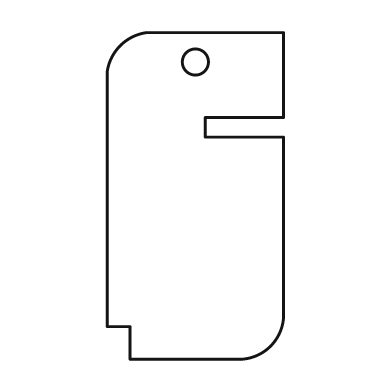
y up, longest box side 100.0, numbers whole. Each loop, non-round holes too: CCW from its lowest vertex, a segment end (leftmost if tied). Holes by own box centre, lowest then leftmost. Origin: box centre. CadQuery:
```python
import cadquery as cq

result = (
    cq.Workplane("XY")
    .moveTo(-20.0, -50.0)
    .lineTo(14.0, -50.0)
    .threePointArc((23.0, -46.0), (27.0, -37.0))
    .lineTo(27.0, 18.0)
    .lineTo(3.0, 18.0)
    .lineTo(3.0, 24.0)
    .lineTo(27.0, 24.0)
    .lineTo(27.0, 50.0)
    .lineTo(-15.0, 50.0)
    .threePointArc((-23.0, 46.0), (-27.0, 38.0))
    .lineTo(-27.0, -40.0)
    .lineTo(-20.0, -40.0)
    .close()
    .moveTo(0.0, 41.0)
    .circle(4.0)
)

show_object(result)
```